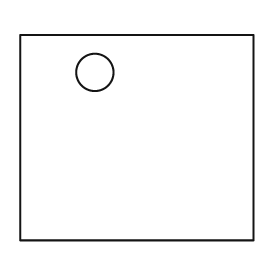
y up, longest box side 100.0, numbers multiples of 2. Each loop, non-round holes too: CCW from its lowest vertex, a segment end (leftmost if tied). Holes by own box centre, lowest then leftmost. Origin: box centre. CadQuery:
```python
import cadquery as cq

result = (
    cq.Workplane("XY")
    .moveTo(-50.0, -44.0)
    .lineTo(50.0, -44.0)
    .lineTo(50.0, 44.0)
    .lineTo(-50.0, 44.0)
    .close()
    .moveTo(-18.0, 28.0)
    .circle(8.0)
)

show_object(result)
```